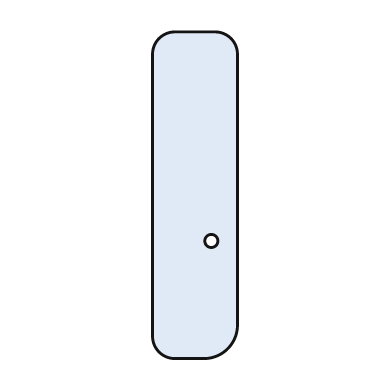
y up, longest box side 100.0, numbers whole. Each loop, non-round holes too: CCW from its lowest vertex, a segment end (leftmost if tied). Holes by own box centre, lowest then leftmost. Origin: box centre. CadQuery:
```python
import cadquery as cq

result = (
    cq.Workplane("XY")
    .moveTo(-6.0, -50.0)
    .lineTo(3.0, -50.0)
    .threePointArc((10.0, -47.0), (13.0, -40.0))
    .lineTo(13.0, 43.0)
    .threePointArc((11.0, 48.0), (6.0, 50.0))
    .lineTo(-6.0, 50.0)
    .threePointArc((-11.0, 48.0), (-13.0, 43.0))
    .lineTo(-13.0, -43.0)
    .threePointArc((-11.0, -48.0), (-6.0, -50.0))
    .close()
    .moveTo(5.0, -14.0)
    .circle(2.0)
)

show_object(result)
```